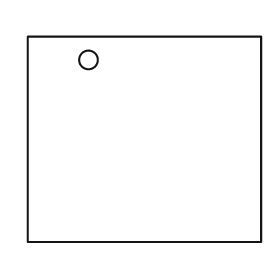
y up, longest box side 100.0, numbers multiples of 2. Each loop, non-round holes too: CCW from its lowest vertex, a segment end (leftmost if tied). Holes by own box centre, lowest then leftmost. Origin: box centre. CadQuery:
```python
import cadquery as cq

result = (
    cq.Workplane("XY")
    .moveTo(-50.0, -44.0)
    .lineTo(50.0, -44.0)
    .lineTo(50.0, 44.0)
    .lineTo(-50.0, 44.0)
    .close()
    .moveTo(-24.0, 34.0)
    .circle(4.0)
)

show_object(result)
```